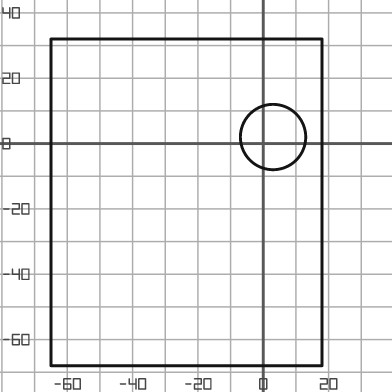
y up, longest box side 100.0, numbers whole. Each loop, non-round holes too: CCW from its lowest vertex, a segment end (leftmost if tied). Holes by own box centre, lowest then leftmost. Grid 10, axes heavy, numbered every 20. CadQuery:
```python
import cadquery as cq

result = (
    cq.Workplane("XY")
    .moveTo(-65.0, -68.0)
    .lineTo(18.0, -68.0)
    .lineTo(18.0, 32.0)
    .lineTo(-65.0, 32.0)
    .close()
    .moveTo(3.0, 2.0)
    .circle(10.0)
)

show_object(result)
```